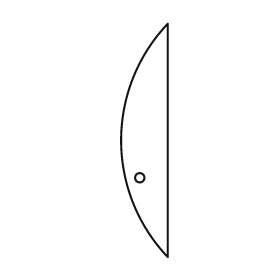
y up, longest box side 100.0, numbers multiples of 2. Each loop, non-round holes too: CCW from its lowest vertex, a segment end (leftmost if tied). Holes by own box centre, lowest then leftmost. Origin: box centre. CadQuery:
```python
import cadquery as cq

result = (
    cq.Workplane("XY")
    .moveTo(10.0, -50.0)
    .lineTo(10.0, 50.0)
    .threePointArc((-10.0, 0.0), (10.0, -50.0))
    .close()
    .moveTo(-2.0, -16.0)
    .circle(2.0)
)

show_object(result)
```